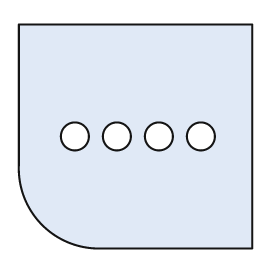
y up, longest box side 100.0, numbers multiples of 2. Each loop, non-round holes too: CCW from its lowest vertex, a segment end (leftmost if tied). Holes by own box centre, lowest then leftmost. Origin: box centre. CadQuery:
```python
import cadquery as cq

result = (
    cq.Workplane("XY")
    .moveTo(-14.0, -48.0)
    .lineTo(50.0, -48.0)
    .lineTo(50.0, 48.0)
    .lineTo(-50.0, 48.0)
    .lineTo(-50.0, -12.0)
    .threePointArc((-40.0, -38.0), (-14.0, -48.0))
    .close()
    .moveTo(-26.0, 0.0)
    .circle(6.0)
    .moveTo(-8.0, 0.0)
    .circle(6.0)
    .moveTo(10.0, 0.0)
    .circle(6.0)
    .moveTo(28.0, 0.0)
    .circle(6.0)
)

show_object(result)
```